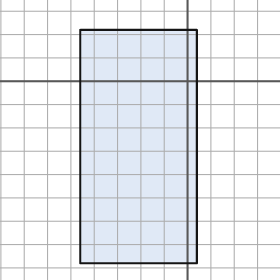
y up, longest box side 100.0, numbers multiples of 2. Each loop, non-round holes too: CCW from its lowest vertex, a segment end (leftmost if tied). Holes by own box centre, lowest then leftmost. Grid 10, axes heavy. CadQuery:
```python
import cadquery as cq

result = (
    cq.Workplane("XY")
    .moveTo(-46.0, -78.0)
    .lineTo(4.0, -78.0)
    .lineTo(4.0, 22.0)
    .lineTo(-46.0, 22.0)
    .close()
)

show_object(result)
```